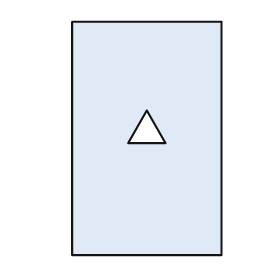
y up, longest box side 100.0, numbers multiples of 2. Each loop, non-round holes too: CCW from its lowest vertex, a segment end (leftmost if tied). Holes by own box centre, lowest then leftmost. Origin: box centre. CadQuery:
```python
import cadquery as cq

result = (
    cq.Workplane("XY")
    .moveTo(-32.0, -50.0)
    .lineTo(32.0, -50.0)
    .lineTo(32.0, 50.0)
    .lineTo(-32.0, 50.0)
    .close()
    .moveTo(-8.0, -2.0)
    .lineTo(8.0, -2.0)
    .lineTo(0.0, 12.0)
    .close()
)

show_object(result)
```